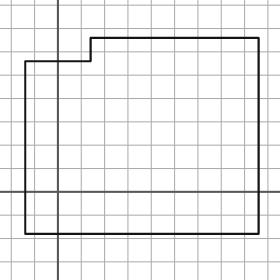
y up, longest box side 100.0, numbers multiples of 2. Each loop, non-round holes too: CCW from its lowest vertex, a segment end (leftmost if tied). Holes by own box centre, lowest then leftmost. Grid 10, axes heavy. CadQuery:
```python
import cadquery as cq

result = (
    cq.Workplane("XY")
    .moveTo(-14.0, -18.0)
    .lineTo(86.0, -18.0)
    .lineTo(86.0, 66.0)
    .lineTo(14.0, 66.0)
    .lineTo(14.0, 56.0)
    .lineTo(-14.0, 56.0)
    .close()
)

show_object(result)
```